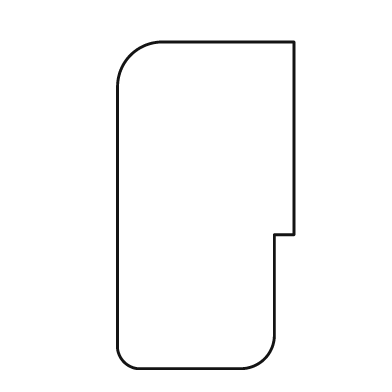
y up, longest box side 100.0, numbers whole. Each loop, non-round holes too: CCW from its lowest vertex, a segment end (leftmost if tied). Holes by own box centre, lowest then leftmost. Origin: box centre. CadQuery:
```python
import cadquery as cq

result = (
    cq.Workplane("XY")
    .moveTo(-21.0, -50.0)
    .lineTo(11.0, -50.0)
    .threePointArc((18.0, -47.0), (21.0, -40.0))
    .lineTo(21.0, -9.0)
    .lineTo(27.0, -9.0)
    .lineTo(27.0, 50.0)
    .lineTo(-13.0, 50.0)
    .threePointArc((-23.0, 46.0), (-27.0, 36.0))
    .lineTo(-27.0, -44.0)
    .threePointArc((-25.0, -48.0), (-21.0, -50.0))
    .close()
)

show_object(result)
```